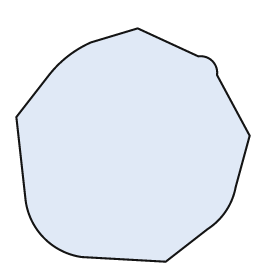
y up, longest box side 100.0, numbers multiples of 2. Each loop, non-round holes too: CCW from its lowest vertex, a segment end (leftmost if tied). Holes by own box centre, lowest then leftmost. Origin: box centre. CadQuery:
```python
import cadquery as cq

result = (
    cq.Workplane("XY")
    .moveTo(14.0, -50.0)
    .lineTo(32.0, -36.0)
    .threePointArc((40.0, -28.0), (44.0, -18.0))
    .lineTo(50.0, 4.0)
    .lineTo(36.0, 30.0)
    .threePointArc((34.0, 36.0), (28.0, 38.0))
    .lineTo(2.0, 50.0)
    .lineTo(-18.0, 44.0)
    .threePointArc((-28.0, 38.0), (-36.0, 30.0))
    .lineTo(-50.0, 12.0)
    .lineTo(-46.0, -24.0)
    .threePointArc((-38.0, -40.0), (-22.0, -48.0))
    .close()
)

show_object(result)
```